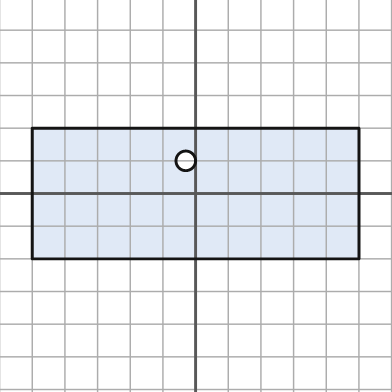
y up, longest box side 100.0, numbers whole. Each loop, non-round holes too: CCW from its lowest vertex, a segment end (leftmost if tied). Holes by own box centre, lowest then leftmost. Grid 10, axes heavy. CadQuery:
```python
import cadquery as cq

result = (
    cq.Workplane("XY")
    .moveTo(-50.0, -20.0)
    .lineTo(50.0, -20.0)
    .lineTo(50.0, 20.0)
    .lineTo(-50.0, 20.0)
    .close()
    .moveTo(-3.0, 10.0)
    .circle(3.0)
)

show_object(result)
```